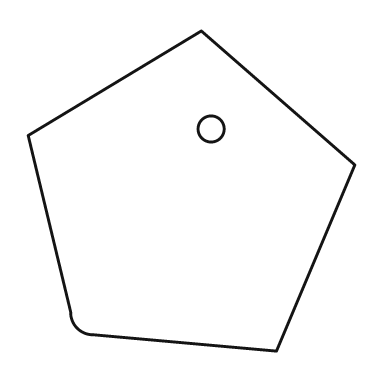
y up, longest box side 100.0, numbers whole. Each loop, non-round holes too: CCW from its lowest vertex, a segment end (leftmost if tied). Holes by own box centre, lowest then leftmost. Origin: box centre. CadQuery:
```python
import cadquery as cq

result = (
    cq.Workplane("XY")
    .moveTo(26.0, -49.0)
    .lineTo(50.0, 8.0)
    .lineTo(3.0, 49.0)
    .lineTo(-50.0, 17.0)
    .lineTo(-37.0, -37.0)
    .threePointArc((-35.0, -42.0), (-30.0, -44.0))
    .close()
    .moveTo(6.0, 19.0)
    .circle(4.0)
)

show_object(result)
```